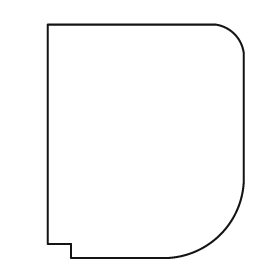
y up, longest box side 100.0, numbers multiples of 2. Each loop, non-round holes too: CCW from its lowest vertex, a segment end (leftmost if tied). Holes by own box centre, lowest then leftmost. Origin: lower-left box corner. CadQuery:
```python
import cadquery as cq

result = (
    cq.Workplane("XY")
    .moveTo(10.0, 0.0)
    .lineTo(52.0, 0.0)
    .threePointArc((74.0, 10.0), (84.0, 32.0))
    .lineTo(84.0, 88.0)
    .threePointArc((80.0, 96.0), (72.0, 100.0))
    .lineTo(0.0, 100.0)
    .lineTo(0.0, 6.0)
    .lineTo(10.0, 6.0)
    .close()
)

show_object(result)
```